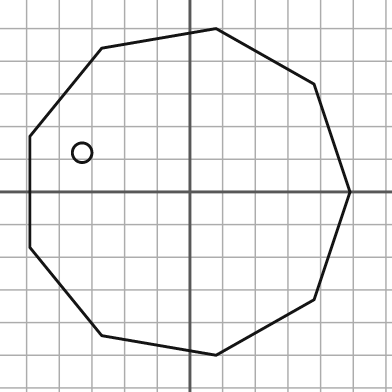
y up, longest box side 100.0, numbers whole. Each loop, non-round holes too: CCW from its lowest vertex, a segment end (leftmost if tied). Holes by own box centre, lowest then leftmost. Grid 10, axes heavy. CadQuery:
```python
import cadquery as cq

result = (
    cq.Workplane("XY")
    .moveTo(8.0, -50.0)
    .lineTo(38.0, -33.0)
    .lineTo(49.0, 0.0)
    .lineTo(38.0, 33.0)
    .lineTo(8.0, 50.0)
    .lineTo(-27.0, 44.0)
    .lineTo(-49.0, 17.0)
    .lineTo(-49.0, -17.0)
    .lineTo(-27.0, -44.0)
    .close()
    .moveTo(-33.0, 12.0)
    .circle(3.0)
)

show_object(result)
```